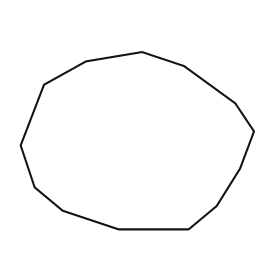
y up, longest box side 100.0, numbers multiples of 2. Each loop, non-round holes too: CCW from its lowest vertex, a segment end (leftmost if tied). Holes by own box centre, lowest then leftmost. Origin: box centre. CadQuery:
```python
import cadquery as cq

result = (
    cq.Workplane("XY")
    .moveTo(-8.0, -38.0)
    .lineTo(22.0, -38.0)
    .lineTo(34.0, -28.0)
    .lineTo(44.0, -12.0)
    .lineTo(50.0, 4.0)
    .lineTo(42.0, 16.0)
    .lineTo(20.0, 32.0)
    .lineTo(2.0, 38.0)
    .lineTo(-22.0, 34.0)
    .lineTo(-40.0, 24.0)
    .lineTo(-50.0, -2.0)
    .lineTo(-44.0, -20.0)
    .lineTo(-32.0, -30.0)
    .close()
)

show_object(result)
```